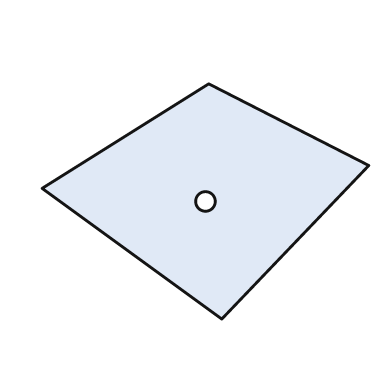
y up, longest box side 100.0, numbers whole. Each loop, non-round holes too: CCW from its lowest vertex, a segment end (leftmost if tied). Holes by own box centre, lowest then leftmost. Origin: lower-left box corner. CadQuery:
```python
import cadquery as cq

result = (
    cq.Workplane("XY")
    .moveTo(55.0, 0.0)
    .lineTo(100.0, 47.0)
    .lineTo(51.0, 72.0)
    .lineTo(0.0, 40.0)
    .close()
    .moveTo(50.0, 36.0)
    .circle(3.0)
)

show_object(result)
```